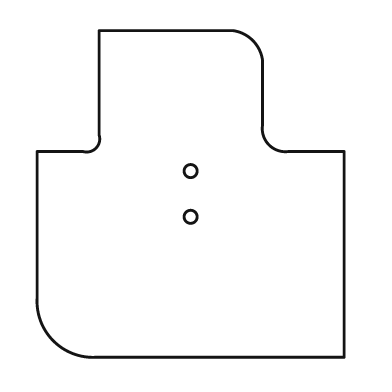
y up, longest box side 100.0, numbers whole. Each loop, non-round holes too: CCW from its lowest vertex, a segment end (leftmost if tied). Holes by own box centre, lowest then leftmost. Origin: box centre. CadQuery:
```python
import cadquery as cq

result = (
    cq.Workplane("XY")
    .moveTo(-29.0, -50.0)
    .lineTo(47.0, -50.0)
    .lineTo(47.0, 13.0)
    .lineTo(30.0, 13.0)
    .threePointArc((24.0, 15.0), (22.0, 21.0))
    .lineTo(22.0, 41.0)
    .threePointArc((19.0, 47.0), (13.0, 50.0))
    .lineTo(-28.0, 50.0)
    .lineTo(-28.0, 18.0)
    .threePointArc((-29.0, 14.0), (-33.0, 13.0))
    .lineTo(-47.0, 13.0)
    .lineTo(-47.0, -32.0)
    .threePointArc((-42.0, -45.0), (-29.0, -50.0))
    .close()
    .moveTo(0.0, -7.0)
    .circle(2.0)
    .moveTo(0.0, 7.0)
    .circle(2.0)
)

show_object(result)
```